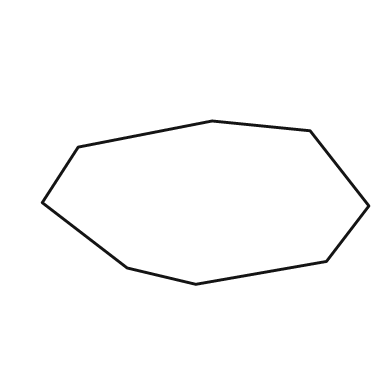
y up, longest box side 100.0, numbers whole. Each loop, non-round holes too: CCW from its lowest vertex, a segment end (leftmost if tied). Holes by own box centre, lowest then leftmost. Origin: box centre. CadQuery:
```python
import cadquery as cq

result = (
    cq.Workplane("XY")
    .moveTo(-3.0, -25.0)
    .lineTo(37.0, -18.0)
    .lineTo(50.0, -1.0)
    .lineTo(32.0, 22.0)
    .lineTo(2.0, 25.0)
    .lineTo(-39.0, 17.0)
    .lineTo(-50.0, 0.0)
    .lineTo(-24.0, -20.0)
    .close()
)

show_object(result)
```